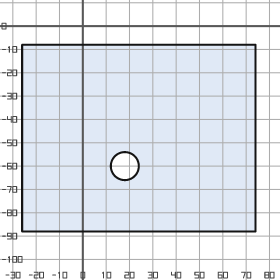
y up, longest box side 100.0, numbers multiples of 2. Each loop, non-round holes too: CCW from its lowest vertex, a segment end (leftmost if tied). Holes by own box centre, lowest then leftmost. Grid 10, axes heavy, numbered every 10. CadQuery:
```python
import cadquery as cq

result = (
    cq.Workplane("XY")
    .moveTo(-26.0, -88.0)
    .lineTo(74.0, -88.0)
    .lineTo(74.0, -8.0)
    .lineTo(-26.0, -8.0)
    .close()
    .moveTo(18.0, -60.0)
    .circle(6.0)
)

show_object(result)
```